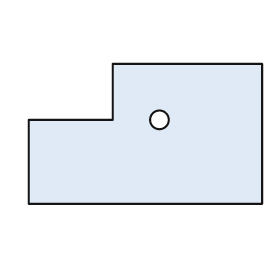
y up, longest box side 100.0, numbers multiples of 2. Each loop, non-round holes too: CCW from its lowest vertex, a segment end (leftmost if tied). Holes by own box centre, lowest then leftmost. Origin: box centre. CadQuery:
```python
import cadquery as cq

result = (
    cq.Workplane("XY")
    .moveTo(-50.0, -30.0)
    .lineTo(50.0, -30.0)
    .lineTo(50.0, 30.0)
    .lineTo(-14.0, 30.0)
    .lineTo(-14.0, 6.0)
    .lineTo(-50.0, 6.0)
    .close()
    .moveTo(6.0, 6.0)
    .circle(4.0)
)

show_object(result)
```